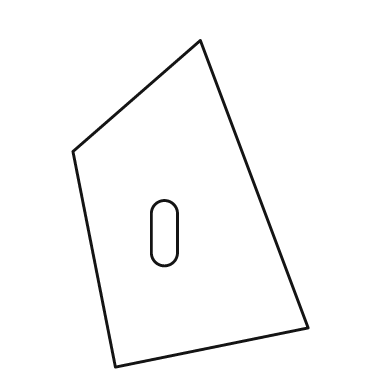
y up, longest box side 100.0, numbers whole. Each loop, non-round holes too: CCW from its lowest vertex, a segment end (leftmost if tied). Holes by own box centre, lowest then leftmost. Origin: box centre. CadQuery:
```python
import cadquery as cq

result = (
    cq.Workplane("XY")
    .moveTo(-23.0, -50.0)
    .lineTo(36.0, -38.0)
    .lineTo(3.0, 50.0)
    .lineTo(-36.0, 16.0)
    .close()
    .moveTo(-12.0, -15.0)
    .threePointArc((-8.0, -19.0), (-4.0, -15.0))
    .lineTo(-4.0, -3.0)
    .threePointArc((-8.0, 1.0), (-12.0, -3.0))
    .close()
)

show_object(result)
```